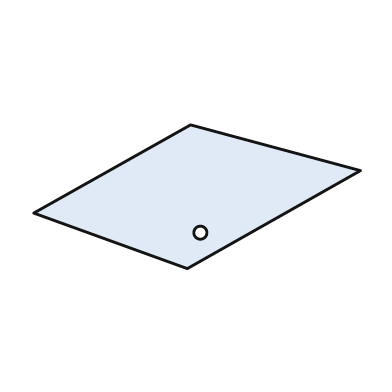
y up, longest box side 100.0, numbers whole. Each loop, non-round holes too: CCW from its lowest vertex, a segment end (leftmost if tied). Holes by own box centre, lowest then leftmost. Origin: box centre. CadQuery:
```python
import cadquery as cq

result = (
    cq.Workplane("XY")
    .moveTo(-3.0, -22.0)
    .lineTo(50.0, 8.0)
    .lineTo(-2.0, 22.0)
    .lineTo(-50.0, -5.0)
    .close()
    .moveTo(1.0, -11.0)
    .circle(2.0)
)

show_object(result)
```